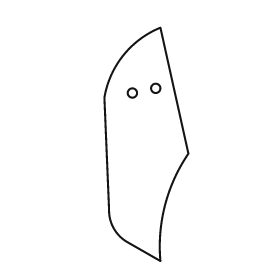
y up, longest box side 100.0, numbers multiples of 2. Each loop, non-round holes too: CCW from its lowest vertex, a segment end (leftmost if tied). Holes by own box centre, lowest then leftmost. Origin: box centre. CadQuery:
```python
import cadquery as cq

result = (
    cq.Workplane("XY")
    .moveTo(6.0, -50.0)
    .threePointArc((8.0, -26.0), (18.0, -4.0))
    .lineTo(6.0, 50.0)
    .threePointArc((-10.0, 38.0), (-18.0, 20.0))
    .lineTo(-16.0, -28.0)
    .threePointArc((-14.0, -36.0), (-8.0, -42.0))
    .close()
    .moveTo(-6.0, 22.0)
    .circle(2.0)
    .moveTo(4.0, 24.0)
    .circle(2.0)
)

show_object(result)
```